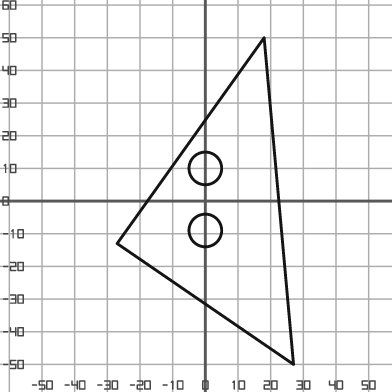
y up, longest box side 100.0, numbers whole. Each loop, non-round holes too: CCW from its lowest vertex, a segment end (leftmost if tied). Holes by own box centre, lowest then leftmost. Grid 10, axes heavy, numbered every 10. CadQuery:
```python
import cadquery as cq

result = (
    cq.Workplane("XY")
    .moveTo(27.0, -50.0)
    .lineTo(18.0, 50.0)
    .lineTo(-27.0, -13.0)
    .close()
    .moveTo(0.0, -9.0)
    .circle(5.0)
    .moveTo(0.0, 10.0)
    .circle(5.0)
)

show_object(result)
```